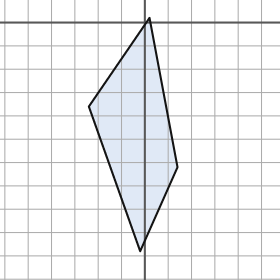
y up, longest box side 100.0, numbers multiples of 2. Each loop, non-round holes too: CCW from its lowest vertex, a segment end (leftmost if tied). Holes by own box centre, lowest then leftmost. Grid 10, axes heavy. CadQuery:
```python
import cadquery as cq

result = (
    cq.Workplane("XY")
    .moveTo(-2.0, -98.0)
    .lineTo(14.0, -62.0)
    .lineTo(2.0, 2.0)
    .lineTo(-24.0, -36.0)
    .close()
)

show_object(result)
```